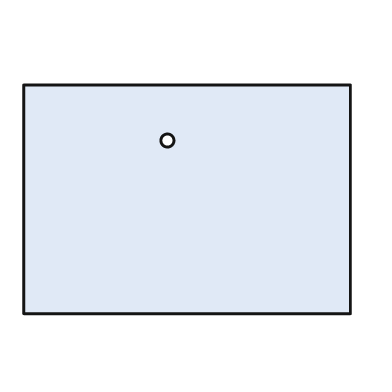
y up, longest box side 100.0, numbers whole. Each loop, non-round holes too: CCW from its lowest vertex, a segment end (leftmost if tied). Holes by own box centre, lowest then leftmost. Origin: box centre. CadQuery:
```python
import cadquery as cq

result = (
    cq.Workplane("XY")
    .moveTo(-50.0, -35.0)
    .lineTo(50.0, -35.0)
    .lineTo(50.0, 35.0)
    .lineTo(-50.0, 35.0)
    .close()
    .moveTo(-6.0, 18.0)
    .circle(2.0)
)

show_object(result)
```